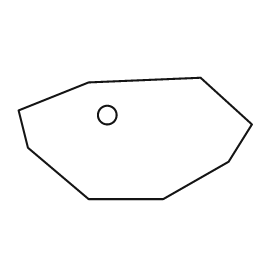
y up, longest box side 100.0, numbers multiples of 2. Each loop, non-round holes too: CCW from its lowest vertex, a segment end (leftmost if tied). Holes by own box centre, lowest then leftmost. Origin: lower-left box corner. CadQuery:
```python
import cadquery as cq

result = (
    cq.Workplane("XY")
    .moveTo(30.0, 0.0)
    .lineTo(62.0, 0.0)
    .lineTo(90.0, 16.0)
    .lineTo(100.0, 32.0)
    .lineTo(78.0, 52.0)
    .lineTo(30.0, 50.0)
    .lineTo(0.0, 38.0)
    .lineTo(4.0, 22.0)
    .close()
    .moveTo(38.0, 36.0)
    .circle(4.0)
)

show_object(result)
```